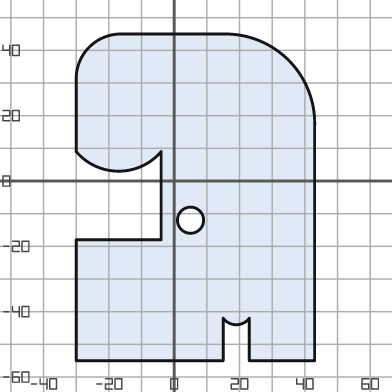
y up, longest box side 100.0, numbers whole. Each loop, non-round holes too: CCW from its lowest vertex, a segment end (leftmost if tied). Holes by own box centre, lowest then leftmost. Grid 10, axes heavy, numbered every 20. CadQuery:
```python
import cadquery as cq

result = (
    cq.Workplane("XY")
    .moveTo(-30.0, -55.0)
    .lineTo(15.0, -55.0)
    .lineTo(15.0, -42.0)
    .threePointArc((19.0, -44.0), (23.0, -42.0))
    .lineTo(23.0, -55.0)
    .lineTo(43.0, -55.0)
    .lineTo(43.0, 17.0)
    .threePointArc((35.0, 37.0), (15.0, 45.0))
    .lineTo(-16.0, 45.0)
    .threePointArc((-26.0, 41.0), (-30.0, 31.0))
    .lineTo(-30.0, 9.0)
    .threePointArc((-17.0, 3.0), (-4.0, 9.0))
    .lineTo(-4.0, -18.0)
    .lineTo(-30.0, -18.0)
    .close()
    .moveTo(5.0, -12.0)
    .circle(4.0)
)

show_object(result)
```